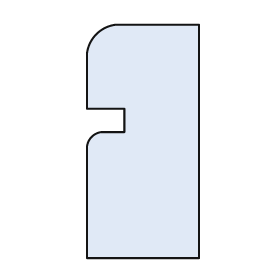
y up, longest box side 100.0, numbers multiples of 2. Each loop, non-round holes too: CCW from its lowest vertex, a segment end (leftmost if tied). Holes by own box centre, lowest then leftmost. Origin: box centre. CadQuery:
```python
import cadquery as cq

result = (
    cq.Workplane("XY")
    .moveTo(-24.0, -50.0)
    .lineTo(24.0, -50.0)
    .lineTo(24.0, 50.0)
    .lineTo(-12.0, 50.0)
    .threePointArc((-20.0, 46.0), (-24.0, 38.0))
    .lineTo(-24.0, 14.0)
    .lineTo(-8.0, 14.0)
    .lineTo(-8.0, 4.0)
    .lineTo(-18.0, 4.0)
    .threePointArc((-22.0, 2.0), (-24.0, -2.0))
    .close()
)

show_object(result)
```